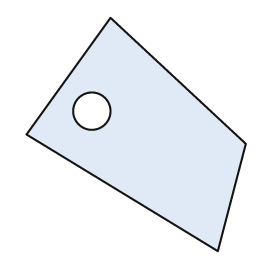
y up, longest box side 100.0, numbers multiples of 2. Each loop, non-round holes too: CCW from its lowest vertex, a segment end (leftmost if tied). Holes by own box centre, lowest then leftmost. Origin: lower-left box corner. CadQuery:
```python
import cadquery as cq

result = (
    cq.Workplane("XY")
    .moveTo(82.0, 0.0)
    .lineTo(94.0, 46.0)
    .lineTo(36.0, 100.0)
    .lineTo(0.0, 50.0)
    .close()
    .moveTo(28.0, 60.0)
    .circle(8.0)
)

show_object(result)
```